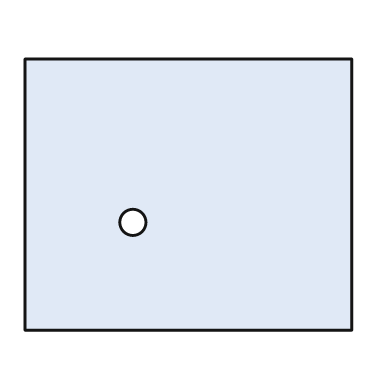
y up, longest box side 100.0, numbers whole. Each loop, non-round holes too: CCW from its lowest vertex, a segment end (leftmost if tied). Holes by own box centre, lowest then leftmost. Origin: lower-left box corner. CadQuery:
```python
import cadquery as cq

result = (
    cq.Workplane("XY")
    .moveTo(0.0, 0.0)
    .lineTo(100.0, 0.0)
    .lineTo(100.0, 83.0)
    .lineTo(0.0, 83.0)
    .close()
    .moveTo(33.0, 33.0)
    .circle(4.0)
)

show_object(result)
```